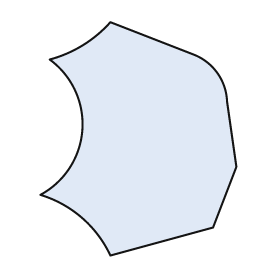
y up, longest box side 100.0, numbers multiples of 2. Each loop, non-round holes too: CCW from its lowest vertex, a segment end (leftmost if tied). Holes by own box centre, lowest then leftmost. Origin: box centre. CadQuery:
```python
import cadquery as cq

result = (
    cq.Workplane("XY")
    .moveTo(-12.0, -50.0)
    .lineTo(32.0, -38.0)
    .lineTo(42.0, -12.0)
    .lineTo(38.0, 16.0)
    .threePointArc((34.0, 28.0), (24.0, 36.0))
    .lineTo(-12.0, 50.0)
    .threePointArc((-24.0, 40.0), (-38.0, 34.0))
    .threePointArc((-24.0, 4.0), (-42.0, -24.0))
    .threePointArc((-24.0, -34.0), (-12.0, -50.0))
    .close()
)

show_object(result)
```